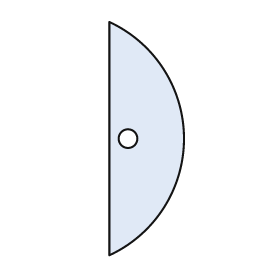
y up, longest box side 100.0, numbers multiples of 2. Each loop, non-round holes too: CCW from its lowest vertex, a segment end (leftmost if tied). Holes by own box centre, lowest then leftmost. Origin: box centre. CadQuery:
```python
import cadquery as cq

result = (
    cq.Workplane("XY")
    .moveTo(-16.0, -50.0)
    .threePointArc((16.0, 0.0), (-16.0, 50.0))
    .close()
    .moveTo(-8.0, 0.0)
    .circle(4.0)
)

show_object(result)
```